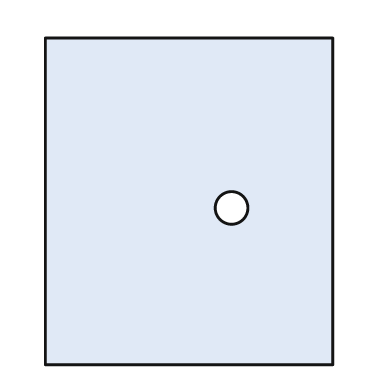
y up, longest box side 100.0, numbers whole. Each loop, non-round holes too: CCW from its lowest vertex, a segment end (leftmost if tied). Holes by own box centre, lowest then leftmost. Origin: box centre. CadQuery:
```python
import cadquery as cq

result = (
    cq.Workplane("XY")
    .moveTo(-44.0, -50.0)
    .lineTo(44.0, -50.0)
    .lineTo(44.0, 50.0)
    .lineTo(-44.0, 50.0)
    .close()
    .moveTo(13.0, -2.0)
    .circle(5.0)
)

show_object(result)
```